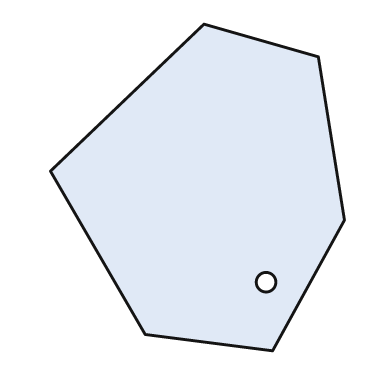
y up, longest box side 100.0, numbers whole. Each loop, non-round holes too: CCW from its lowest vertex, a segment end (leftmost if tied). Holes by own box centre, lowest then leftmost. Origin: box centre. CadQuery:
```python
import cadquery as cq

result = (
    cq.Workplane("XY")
    .moveTo(23.0, -50.0)
    .lineTo(45.0, -10.0)
    .lineTo(37.0, 40.0)
    .lineTo(2.0, 50.0)
    .lineTo(-45.0, 5.0)
    .lineTo(-16.0, -45.0)
    .close()
    .moveTo(21.0, -29.0)
    .circle(3.0)
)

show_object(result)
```